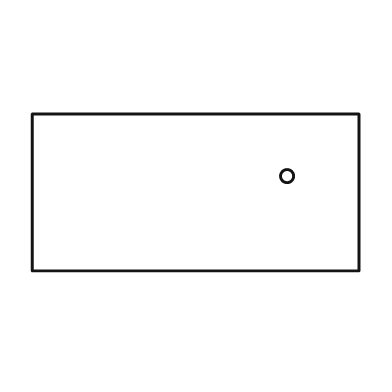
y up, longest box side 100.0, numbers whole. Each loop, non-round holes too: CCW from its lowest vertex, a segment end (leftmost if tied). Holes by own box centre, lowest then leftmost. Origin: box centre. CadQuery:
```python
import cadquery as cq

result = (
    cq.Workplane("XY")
    .moveTo(-50.0, -24.0)
    .lineTo(50.0, -24.0)
    .lineTo(50.0, 24.0)
    .lineTo(-50.0, 24.0)
    .close()
    .moveTo(28.0, 5.0)
    .circle(2.0)
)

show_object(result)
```